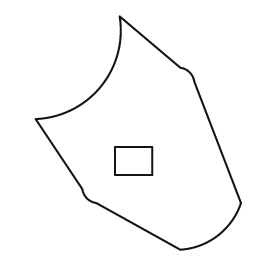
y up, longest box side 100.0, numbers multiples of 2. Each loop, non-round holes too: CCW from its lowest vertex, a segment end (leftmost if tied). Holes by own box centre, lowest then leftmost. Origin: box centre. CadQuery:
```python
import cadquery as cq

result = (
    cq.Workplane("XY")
    .moveTo(18.0, -50.0)
    .threePointArc((34.0, -44.0), (44.0, -30.0))
    .lineTo(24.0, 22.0)
    .threePointArc((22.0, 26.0), (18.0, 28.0))
    .lineTo(-8.0, 50.0)
    .threePointArc((-16.0, 20.0), (-44.0, 6.0))
    .lineTo(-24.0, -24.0)
    .threePointArc((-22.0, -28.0), (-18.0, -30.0))
    .close()
    .moveTo(-10.0, -18.0)
    .lineTo(6.0, -18.0)
    .lineTo(6.0, -6.0)
    .lineTo(-10.0, -6.0)
    .close()
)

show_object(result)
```